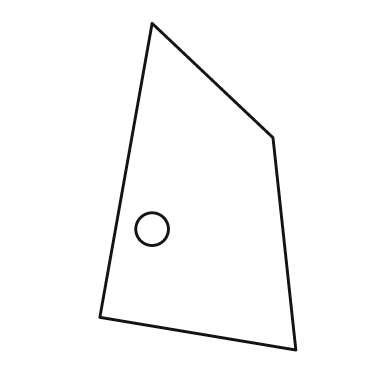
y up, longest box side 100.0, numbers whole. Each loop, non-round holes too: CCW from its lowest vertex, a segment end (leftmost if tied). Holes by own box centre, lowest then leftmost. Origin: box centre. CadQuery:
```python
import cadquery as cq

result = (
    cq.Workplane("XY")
    .moveTo(30.0, -50.0)
    .lineTo(23.0, 15.0)
    .lineTo(-14.0, 50.0)
    .lineTo(-30.0, -40.0)
    .close()
    .moveTo(-14.0, -13.0)
    .circle(5.0)
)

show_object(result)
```